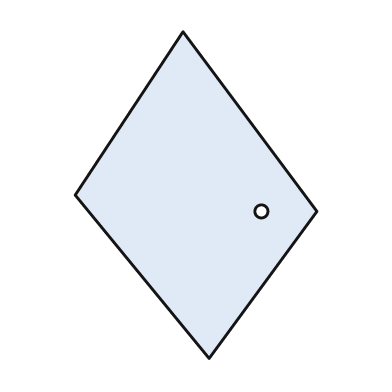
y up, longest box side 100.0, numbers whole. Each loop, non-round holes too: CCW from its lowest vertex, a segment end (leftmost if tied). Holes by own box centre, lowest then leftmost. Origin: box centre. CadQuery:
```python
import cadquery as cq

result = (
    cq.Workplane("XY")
    .moveTo(4.0, -50.0)
    .lineTo(37.0, -5.0)
    .lineTo(-4.0, 50.0)
    .lineTo(-37.0, 0.0)
    .close()
    .moveTo(20.0, -5.0)
    .circle(2.0)
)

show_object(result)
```